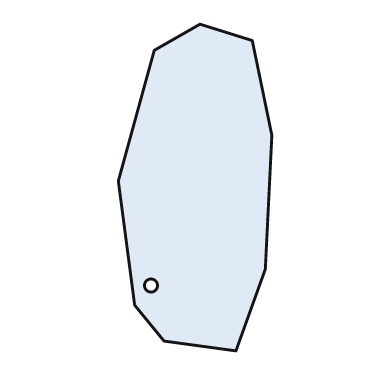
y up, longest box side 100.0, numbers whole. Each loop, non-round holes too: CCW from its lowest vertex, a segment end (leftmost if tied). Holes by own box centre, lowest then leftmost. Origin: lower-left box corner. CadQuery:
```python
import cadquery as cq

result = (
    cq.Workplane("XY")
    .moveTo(36.0, 0.0)
    .lineTo(45.0, 25.0)
    .lineTo(47.0, 66.0)
    .lineTo(41.0, 95.0)
    .lineTo(25.0, 100.0)
    .lineTo(11.0, 92.0)
    .lineTo(0.0, 52.0)
    .lineTo(5.0, 14.0)
    .lineTo(14.0, 3.0)
    .close()
    .moveTo(10.0, 20.0)
    .circle(2.0)
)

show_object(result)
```